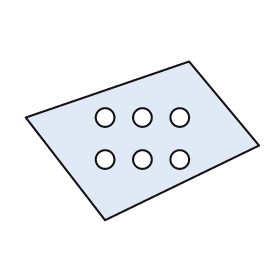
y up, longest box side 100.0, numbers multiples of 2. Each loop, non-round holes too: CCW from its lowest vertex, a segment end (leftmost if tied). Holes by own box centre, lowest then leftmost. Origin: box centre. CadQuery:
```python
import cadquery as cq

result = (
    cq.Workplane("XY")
    .moveTo(-16.0, -34.0)
    .lineTo(50.0, -2.0)
    .lineTo(20.0, 34.0)
    .lineTo(-50.0, 10.0)
    .close()
    .moveTo(-16.0, -8.0)
    .circle(4.0)
    .moveTo(0.0, -8.0)
    .circle(4.0)
    .moveTo(16.0, -8.0)
    .circle(4.0)
    .moveTo(-16.0, 10.0)
    .circle(4.0)
    .moveTo(0.0, 10.0)
    .circle(4.0)
    .moveTo(16.0, 10.0)
    .circle(4.0)
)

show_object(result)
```